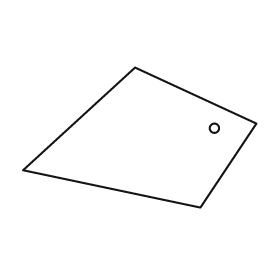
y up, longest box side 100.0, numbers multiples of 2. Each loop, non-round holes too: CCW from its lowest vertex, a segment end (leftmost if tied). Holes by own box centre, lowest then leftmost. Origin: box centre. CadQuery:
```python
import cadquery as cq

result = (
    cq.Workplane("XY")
    .moveTo(26.0, -30.0)
    .lineTo(50.0, 6.0)
    .lineTo(-2.0, 30.0)
    .lineTo(-50.0, -14.0)
    .close()
    .moveTo(32.0, 4.0)
    .circle(2.0)
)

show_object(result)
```